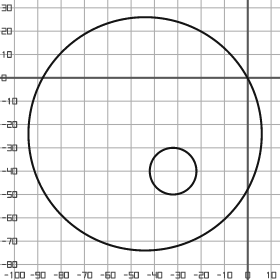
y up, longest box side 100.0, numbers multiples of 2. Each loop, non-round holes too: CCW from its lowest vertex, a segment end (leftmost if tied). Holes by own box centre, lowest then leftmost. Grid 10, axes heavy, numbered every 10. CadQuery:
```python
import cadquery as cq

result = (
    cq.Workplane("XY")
    .moveTo(-44.0, -24.0)
    .circle(50.0)
    .moveTo(-32.0, -40.0)
    .circle(10.0)
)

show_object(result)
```